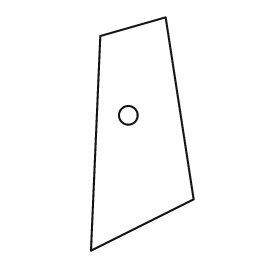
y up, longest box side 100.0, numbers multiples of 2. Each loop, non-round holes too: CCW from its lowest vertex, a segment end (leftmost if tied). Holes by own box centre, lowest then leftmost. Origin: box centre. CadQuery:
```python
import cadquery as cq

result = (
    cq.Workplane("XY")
    .moveTo(-22.0, -50.0)
    .lineTo(22.0, -28.0)
    .lineTo(10.0, 50.0)
    .lineTo(-18.0, 42.0)
    .close()
    .moveTo(-6.0, 8.0)
    .circle(4.0)
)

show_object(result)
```